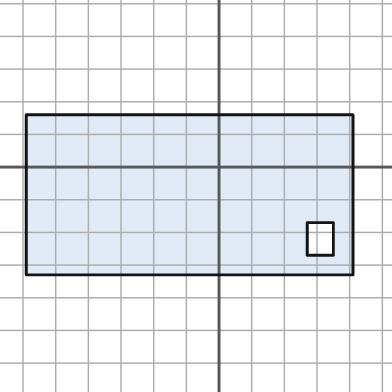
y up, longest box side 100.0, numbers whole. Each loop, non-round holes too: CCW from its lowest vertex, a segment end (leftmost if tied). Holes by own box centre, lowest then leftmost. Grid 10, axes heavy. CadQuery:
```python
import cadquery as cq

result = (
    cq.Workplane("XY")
    .moveTo(-59.0, -33.0)
    .lineTo(41.0, -33.0)
    .lineTo(41.0, 16.0)
    .lineTo(-59.0, 16.0)
    .close()
    .moveTo(27.0, -27.0)
    .lineTo(35.0, -27.0)
    .lineTo(35.0, -17.0)
    .lineTo(27.0, -17.0)
    .close()
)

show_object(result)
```